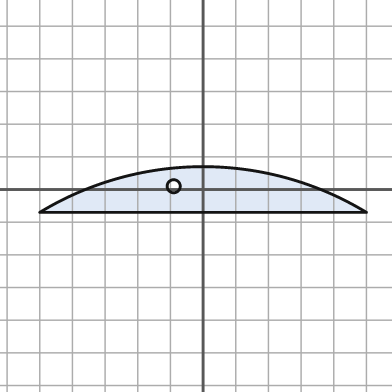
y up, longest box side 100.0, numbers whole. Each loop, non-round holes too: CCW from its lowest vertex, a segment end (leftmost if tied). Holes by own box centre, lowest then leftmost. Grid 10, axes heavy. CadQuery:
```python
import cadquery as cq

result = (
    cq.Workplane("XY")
    .moveTo(-50.0, -7.0)
    .lineTo(50.0, -7.0)
    .threePointArc((0.0, 7.0), (-50.0, -7.0))
    .close()
    .moveTo(-9.0, 1.0)
    .circle(2.0)
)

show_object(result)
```